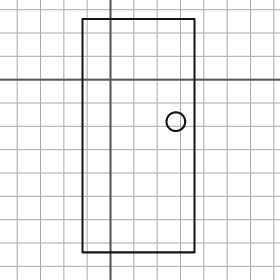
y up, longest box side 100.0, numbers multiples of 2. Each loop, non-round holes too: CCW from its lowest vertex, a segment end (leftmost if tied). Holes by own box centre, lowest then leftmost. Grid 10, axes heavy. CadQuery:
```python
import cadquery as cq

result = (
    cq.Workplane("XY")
    .moveTo(-12.0, -74.0)
    .lineTo(36.0, -74.0)
    .lineTo(36.0, 26.0)
    .lineTo(-12.0, 26.0)
    .close()
    .moveTo(28.0, -18.0)
    .circle(4.0)
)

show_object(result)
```